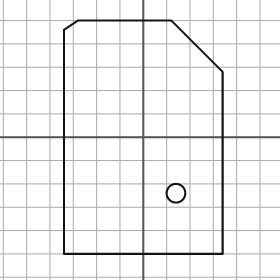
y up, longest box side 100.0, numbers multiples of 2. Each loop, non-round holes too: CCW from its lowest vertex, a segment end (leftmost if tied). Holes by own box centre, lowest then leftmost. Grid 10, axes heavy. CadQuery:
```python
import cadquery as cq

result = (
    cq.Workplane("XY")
    .moveTo(-34.0, -50.0)
    .lineTo(34.0, -50.0)
    .lineTo(34.0, 28.0)
    .lineTo(12.0, 50.0)
    .lineTo(-28.0, 50.0)
    .lineTo(-34.0, 46.0)
    .close()
    .moveTo(14.0, -24.0)
    .circle(4.0)
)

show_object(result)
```